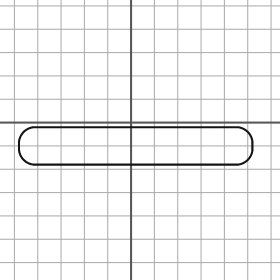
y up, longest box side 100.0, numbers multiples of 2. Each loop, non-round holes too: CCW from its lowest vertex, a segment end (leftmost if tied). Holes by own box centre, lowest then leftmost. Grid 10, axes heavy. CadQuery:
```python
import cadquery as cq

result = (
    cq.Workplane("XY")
    .moveTo(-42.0, -18.0)
    .lineTo(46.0, -18.0)
    .threePointArc((50.0, -16.0), (52.0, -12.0))
    .lineTo(52.0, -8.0)
    .threePointArc((50.0, -4.0), (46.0, -2.0))
    .lineTo(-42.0, -2.0)
    .threePointArc((-46.0, -4.0), (-48.0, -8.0))
    .lineTo(-48.0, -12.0)
    .threePointArc((-46.0, -16.0), (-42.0, -18.0))
    .close()
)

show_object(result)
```